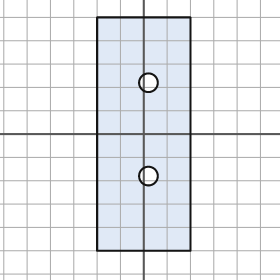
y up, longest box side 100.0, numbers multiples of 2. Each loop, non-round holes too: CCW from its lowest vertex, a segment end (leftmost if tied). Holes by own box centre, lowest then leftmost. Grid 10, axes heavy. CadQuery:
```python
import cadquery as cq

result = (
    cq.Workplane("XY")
    .moveTo(-20.0, -50.0)
    .lineTo(20.0, -50.0)
    .lineTo(20.0, 50.0)
    .lineTo(-20.0, 50.0)
    .close()
    .moveTo(2.0, -18.0)
    .circle(4.0)
    .moveTo(2.0, 22.0)
    .circle(4.0)
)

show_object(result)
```